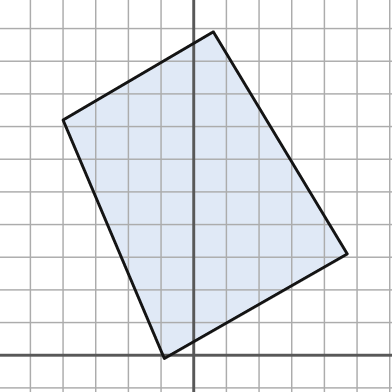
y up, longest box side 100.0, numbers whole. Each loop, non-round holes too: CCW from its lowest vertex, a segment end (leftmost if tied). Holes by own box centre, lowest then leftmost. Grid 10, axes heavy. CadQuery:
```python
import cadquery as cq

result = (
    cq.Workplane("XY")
    .moveTo(-9.0, -1.0)
    .lineTo(47.0, 31.0)
    .lineTo(6.0, 99.0)
    .lineTo(-40.0, 72.0)
    .close()
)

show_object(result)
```